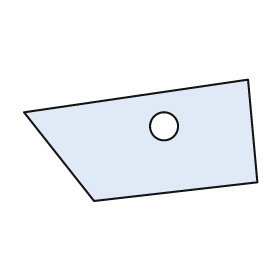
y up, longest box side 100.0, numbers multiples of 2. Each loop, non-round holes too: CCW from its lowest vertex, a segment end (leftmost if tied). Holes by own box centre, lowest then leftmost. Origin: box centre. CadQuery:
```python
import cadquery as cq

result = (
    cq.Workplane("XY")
    .moveTo(-20.0, -26.0)
    .lineTo(50.0, -18.0)
    .lineTo(46.0, 26.0)
    .lineTo(-50.0, 12.0)
    .close()
    .moveTo(10.0, 6.0)
    .circle(6.0)
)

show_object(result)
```